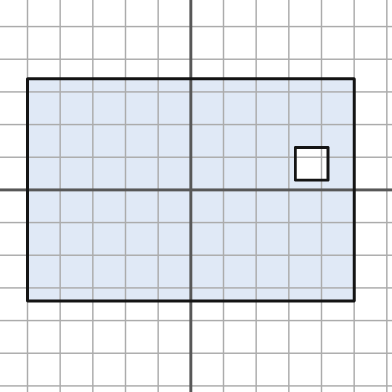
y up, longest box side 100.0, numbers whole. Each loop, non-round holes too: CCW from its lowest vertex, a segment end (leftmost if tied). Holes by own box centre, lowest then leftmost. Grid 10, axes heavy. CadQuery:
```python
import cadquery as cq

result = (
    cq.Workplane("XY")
    .moveTo(-50.0, -34.0)
    .lineTo(50.0, -34.0)
    .lineTo(50.0, 34.0)
    .lineTo(-50.0, 34.0)
    .close()
    .moveTo(32.0, 3.0)
    .lineTo(42.0, 3.0)
    .lineTo(42.0, 13.0)
    .lineTo(32.0, 13.0)
    .close()
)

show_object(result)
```